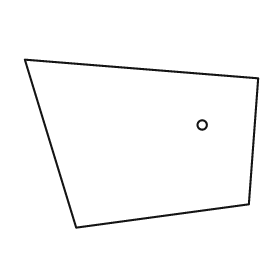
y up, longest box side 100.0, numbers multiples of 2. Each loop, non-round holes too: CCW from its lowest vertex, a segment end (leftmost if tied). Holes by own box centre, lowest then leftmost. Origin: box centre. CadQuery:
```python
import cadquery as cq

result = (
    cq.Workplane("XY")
    .moveTo(-28.0, -36.0)
    .lineTo(46.0, -26.0)
    .lineTo(50.0, 28.0)
    .lineTo(-50.0, 36.0)
    .close()
    .moveTo(26.0, 8.0)
    .circle(2.0)
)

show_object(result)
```